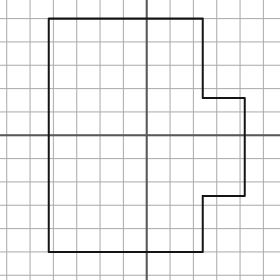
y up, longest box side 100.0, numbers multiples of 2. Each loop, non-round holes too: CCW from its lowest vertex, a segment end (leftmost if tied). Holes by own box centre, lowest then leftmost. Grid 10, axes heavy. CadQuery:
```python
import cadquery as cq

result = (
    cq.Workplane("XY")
    .moveTo(-42.0, -50.0)
    .lineTo(24.0, -50.0)
    .lineTo(24.0, -26.0)
    .lineTo(42.0, -26.0)
    .lineTo(42.0, 16.0)
    .lineTo(24.0, 16.0)
    .lineTo(24.0, 50.0)
    .lineTo(-42.0, 50.0)
    .close()
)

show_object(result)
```